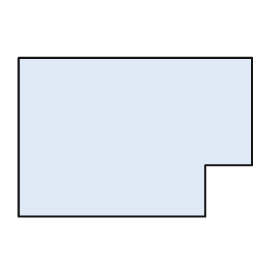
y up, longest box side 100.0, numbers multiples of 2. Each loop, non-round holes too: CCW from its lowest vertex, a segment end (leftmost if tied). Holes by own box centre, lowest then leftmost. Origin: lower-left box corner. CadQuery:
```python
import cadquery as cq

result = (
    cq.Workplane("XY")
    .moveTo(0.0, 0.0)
    .lineTo(80.0, 0.0)
    .lineTo(80.0, 22.0)
    .lineTo(100.0, 22.0)
    .lineTo(100.0, 68.0)
    .lineTo(0.0, 68.0)
    .close()
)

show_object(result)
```